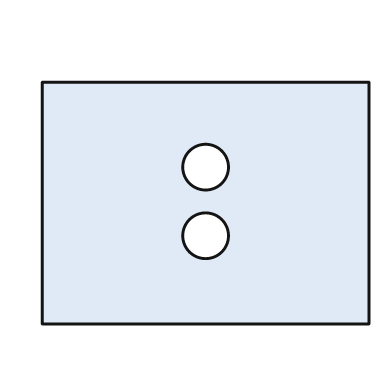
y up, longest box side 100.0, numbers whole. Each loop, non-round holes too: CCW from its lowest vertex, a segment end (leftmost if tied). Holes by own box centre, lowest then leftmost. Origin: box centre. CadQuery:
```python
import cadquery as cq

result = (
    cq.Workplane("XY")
    .moveTo(-50.0, -37.0)
    .lineTo(50.0, -37.0)
    .lineTo(50.0, 37.0)
    .lineTo(-50.0, 37.0)
    .close()
    .moveTo(0.0, -10.0)
    .circle(7.0)
    .moveTo(0.0, 11.0)
    .circle(7.0)
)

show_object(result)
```